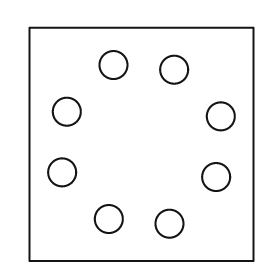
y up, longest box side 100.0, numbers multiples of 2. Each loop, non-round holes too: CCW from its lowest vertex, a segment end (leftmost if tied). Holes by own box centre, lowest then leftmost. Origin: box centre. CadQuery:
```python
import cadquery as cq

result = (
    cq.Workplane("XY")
    .moveTo(-48.0, -50.0)
    .lineTo(48.0, -50.0)
    .lineTo(48.0, 50.0)
    .lineTo(-48.0, 50.0)
    .close()
    .moveTo(12.0, -34.0)
    .circle(6.0)
    .moveTo(-14.0, -32.0)
    .circle(6.0)
    .moveTo(32.0, -14.0)
    .circle(6.0)
    .moveTo(-34.0, -12.0)
    .circle(6.0)
    .moveTo(34.0, 12.0)
    .circle(6.0)
    .moveTo(-32.0, 14.0)
    .circle(6.0)
    .moveTo(14.0, 32.0)
    .circle(6.0)
    .moveTo(-12.0, 34.0)
    .circle(6.0)
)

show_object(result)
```